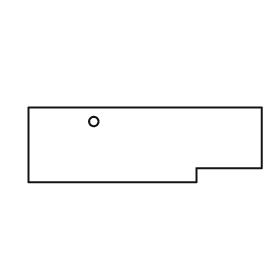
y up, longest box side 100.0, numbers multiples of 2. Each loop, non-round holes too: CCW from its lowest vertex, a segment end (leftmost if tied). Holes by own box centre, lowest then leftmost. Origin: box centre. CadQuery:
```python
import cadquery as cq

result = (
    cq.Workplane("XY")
    .moveTo(-50.0, -16.0)
    .lineTo(22.0, -16.0)
    .lineTo(22.0, -10.0)
    .lineTo(50.0, -10.0)
    .lineTo(50.0, 16.0)
    .lineTo(-50.0, 16.0)
    .close()
    .moveTo(-22.0, 10.0)
    .circle(2.0)
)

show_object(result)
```